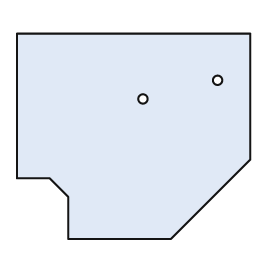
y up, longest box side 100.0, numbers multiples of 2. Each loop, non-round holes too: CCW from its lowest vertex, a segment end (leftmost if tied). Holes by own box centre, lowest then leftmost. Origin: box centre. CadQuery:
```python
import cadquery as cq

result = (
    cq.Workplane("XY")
    .moveTo(-28.0, -44.0)
    .lineTo(16.0, -44.0)
    .lineTo(50.0, -10.0)
    .lineTo(50.0, 44.0)
    .lineTo(-50.0, 44.0)
    .lineTo(-50.0, -18.0)
    .lineTo(-36.0, -18.0)
    .lineTo(-28.0, -26.0)
    .close()
    .moveTo(4.0, 16.0)
    .circle(2.0)
    .moveTo(36.0, 24.0)
    .circle(2.0)
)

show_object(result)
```